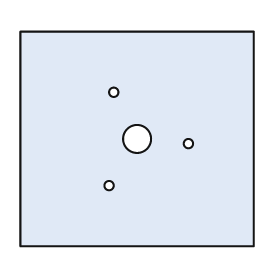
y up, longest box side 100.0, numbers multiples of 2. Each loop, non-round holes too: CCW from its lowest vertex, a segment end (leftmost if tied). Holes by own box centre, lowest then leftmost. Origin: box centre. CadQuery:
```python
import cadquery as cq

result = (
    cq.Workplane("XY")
    .moveTo(-50.0, -46.0)
    .lineTo(50.0, -46.0)
    .lineTo(50.0, 46.0)
    .lineTo(-50.0, 46.0)
    .close()
    .moveTo(-12.0, -20.0)
    .circle(2.0)
    .moveTo(22.0, -2.0)
    .circle(2.0)
    .moveTo(0.0, 0.0)
    .circle(6.0)
    .moveTo(-10.0, 20.0)
    .circle(2.0)
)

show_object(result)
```